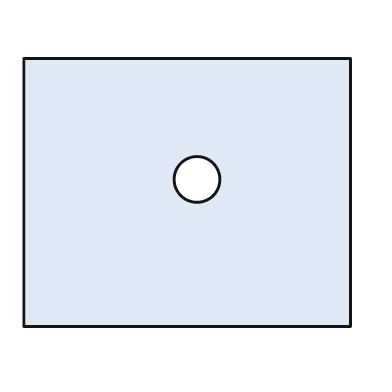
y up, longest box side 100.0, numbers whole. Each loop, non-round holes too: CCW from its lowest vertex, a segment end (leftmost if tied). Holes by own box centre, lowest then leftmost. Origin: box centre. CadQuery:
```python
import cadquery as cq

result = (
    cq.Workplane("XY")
    .moveTo(-50.0, -41.0)
    .lineTo(50.0, -41.0)
    .lineTo(50.0, 41.0)
    .lineTo(-50.0, 41.0)
    .close()
    .moveTo(3.0, 4.0)
    .circle(7.0)
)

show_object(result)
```